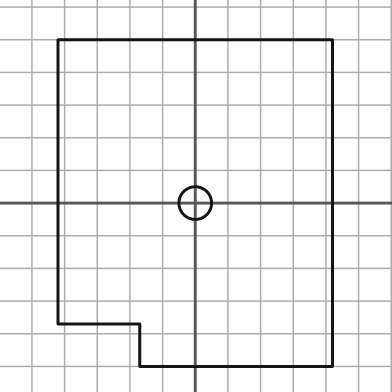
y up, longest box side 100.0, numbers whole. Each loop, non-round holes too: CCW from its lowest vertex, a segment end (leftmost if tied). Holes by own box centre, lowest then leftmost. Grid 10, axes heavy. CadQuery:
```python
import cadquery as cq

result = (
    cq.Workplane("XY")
    .moveTo(-17.0, -50.0)
    .lineTo(42.0, -50.0)
    .lineTo(42.0, 50.0)
    .lineTo(-42.0, 50.0)
    .lineTo(-42.0, -37.0)
    .lineTo(-17.0, -37.0)
    .close()
    .moveTo(0.0, 0.0)
    .circle(5.0)
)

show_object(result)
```